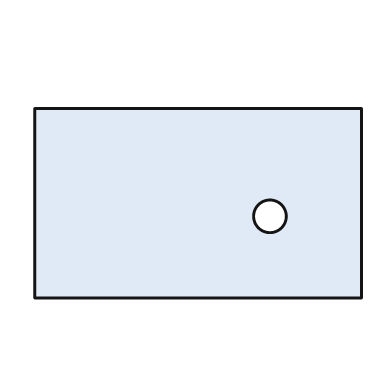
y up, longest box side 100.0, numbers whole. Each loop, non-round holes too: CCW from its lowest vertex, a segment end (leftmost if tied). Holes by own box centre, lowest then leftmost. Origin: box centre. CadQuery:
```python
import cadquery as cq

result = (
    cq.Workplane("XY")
    .moveTo(-50.0, -29.0)
    .lineTo(50.0, -29.0)
    .lineTo(50.0, 29.0)
    .lineTo(-50.0, 29.0)
    .close()
    .moveTo(22.0, -4.0)
    .circle(5.0)
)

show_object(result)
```